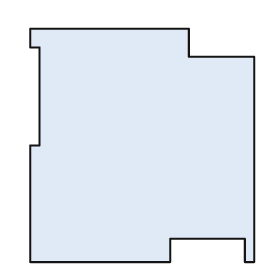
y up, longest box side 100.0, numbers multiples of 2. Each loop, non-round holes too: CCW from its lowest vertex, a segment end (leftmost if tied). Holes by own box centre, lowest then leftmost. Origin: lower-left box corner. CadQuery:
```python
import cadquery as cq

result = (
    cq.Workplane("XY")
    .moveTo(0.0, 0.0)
    .lineTo(60.0, 0.0)
    .lineTo(60.0, 10.0)
    .lineTo(92.0, 10.0)
    .lineTo(92.0, 0.0)
    .lineTo(96.0, 0.0)
    .lineTo(96.0, 88.0)
    .lineTo(68.0, 88.0)
    .lineTo(68.0, 100.0)
    .lineTo(0.0, 100.0)
    .lineTo(0.0, 92.0)
    .lineTo(4.0, 92.0)
    .lineTo(4.0, 50.0)
    .lineTo(0.0, 50.0)
    .close()
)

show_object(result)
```